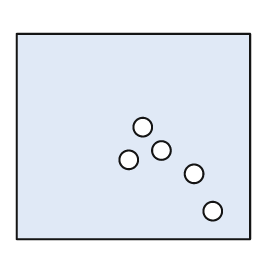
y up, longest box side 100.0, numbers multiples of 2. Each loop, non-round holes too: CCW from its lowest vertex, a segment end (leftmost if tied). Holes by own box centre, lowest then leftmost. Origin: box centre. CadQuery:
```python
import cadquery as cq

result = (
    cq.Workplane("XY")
    .moveTo(-50.0, -44.0)
    .lineTo(50.0, -44.0)
    .lineTo(50.0, 44.0)
    .lineTo(-50.0, 44.0)
    .close()
    .moveTo(34.0, -32.0)
    .circle(4.0)
    .moveTo(26.0, -16.0)
    .circle(4.0)
    .moveTo(-2.0, -10.0)
    .circle(4.0)
    .moveTo(12.0, -6.0)
    .circle(4.0)
    .moveTo(4.0, 4.0)
    .circle(4.0)
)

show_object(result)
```